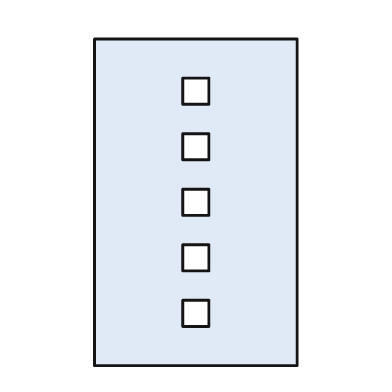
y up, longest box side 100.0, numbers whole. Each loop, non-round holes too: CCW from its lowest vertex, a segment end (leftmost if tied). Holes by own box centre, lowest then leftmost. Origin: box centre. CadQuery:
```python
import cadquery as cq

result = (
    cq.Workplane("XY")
    .moveTo(-31.0, -50.0)
    .lineTo(31.0, -50.0)
    .lineTo(31.0, 50.0)
    .lineTo(-31.0, 50.0)
    .close()
    .moveTo(-4.0, -38.0)
    .lineTo(4.0, -38.0)
    .lineTo(4.0, -30.0)
    .lineTo(-4.0, -30.0)
    .close()
    .moveTo(-4.0, -21.0)
    .lineTo(4.0, -21.0)
    .lineTo(4.0, -13.0)
    .lineTo(-4.0, -13.0)
    .close()
    .moveTo(-4.0, -4.0)
    .lineTo(4.0, -4.0)
    .lineTo(4.0, 4.0)
    .lineTo(-4.0, 4.0)
    .close()
    .moveTo(-4.0, 13.0)
    .lineTo(4.0, 13.0)
    .lineTo(4.0, 21.0)
    .lineTo(-4.0, 21.0)
    .close()
    .moveTo(-4.0, 30.0)
    .lineTo(4.0, 30.0)
    .lineTo(4.0, 38.0)
    .lineTo(-4.0, 38.0)
    .close()
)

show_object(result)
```